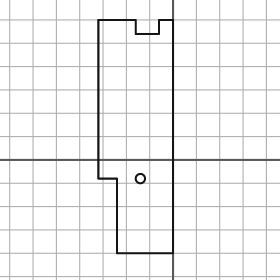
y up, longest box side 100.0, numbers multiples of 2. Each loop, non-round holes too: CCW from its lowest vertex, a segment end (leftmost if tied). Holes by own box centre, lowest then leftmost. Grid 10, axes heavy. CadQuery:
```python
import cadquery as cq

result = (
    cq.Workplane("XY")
    .moveTo(-24.0, -40.0)
    .lineTo(0.0, -40.0)
    .lineTo(0.0, 60.0)
    .lineTo(-6.0, 60.0)
    .lineTo(-6.0, 54.0)
    .lineTo(-16.0, 54.0)
    .lineTo(-16.0, 60.0)
    .lineTo(-32.0, 60.0)
    .lineTo(-32.0, -8.0)
    .lineTo(-24.0, -8.0)
    .close()
    .moveTo(-14.0, -8.0)
    .circle(2.0)
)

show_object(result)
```